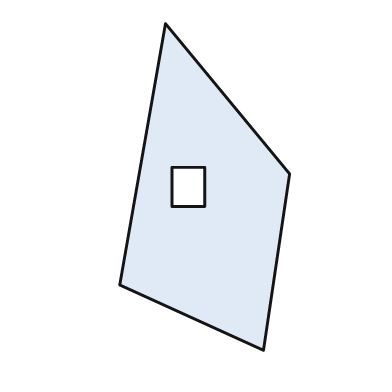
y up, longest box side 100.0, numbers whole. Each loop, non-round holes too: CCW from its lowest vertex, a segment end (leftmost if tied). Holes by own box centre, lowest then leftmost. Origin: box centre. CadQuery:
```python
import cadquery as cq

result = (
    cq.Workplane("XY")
    .moveTo(18.0, -50.0)
    .lineTo(26.0, 4.0)
    .lineTo(-12.0, 50.0)
    .lineTo(-26.0, -30.0)
    .close()
    .moveTo(-10.0, -6.0)
    .lineTo(0.0, -6.0)
    .lineTo(0.0, 6.0)
    .lineTo(-10.0, 6.0)
    .close()
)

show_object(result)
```